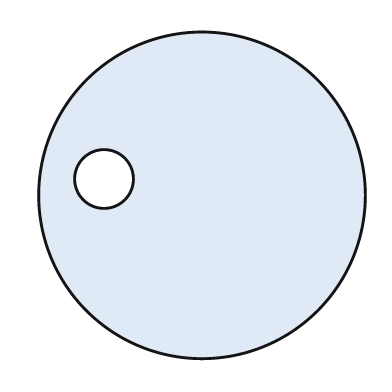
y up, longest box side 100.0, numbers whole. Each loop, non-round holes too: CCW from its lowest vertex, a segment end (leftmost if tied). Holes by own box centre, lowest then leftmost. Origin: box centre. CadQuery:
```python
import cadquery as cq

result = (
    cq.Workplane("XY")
    .moveTo(0.0, 0.0)
    .circle(50.0)
    .moveTo(-30.0, 5.0)
    .circle(9.0)
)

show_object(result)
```